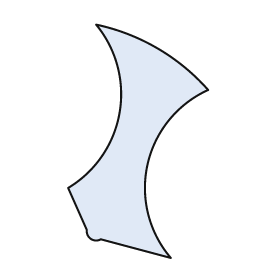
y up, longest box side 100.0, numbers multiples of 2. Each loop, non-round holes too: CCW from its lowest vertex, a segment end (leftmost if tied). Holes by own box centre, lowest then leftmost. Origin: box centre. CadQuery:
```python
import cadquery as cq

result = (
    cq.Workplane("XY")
    .moveTo(14.0, -50.0)
    .threePointArc((4.0, -10.0), (30.0, 22.0))
    .threePointArc((8.0, 40.0), (-18.0, 50.0))
    .threePointArc((-8.0, 12.0), (-30.0, -20.0))
    .lineTo(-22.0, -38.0)
    .threePointArc((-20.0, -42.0), (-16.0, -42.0))
    .close()
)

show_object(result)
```